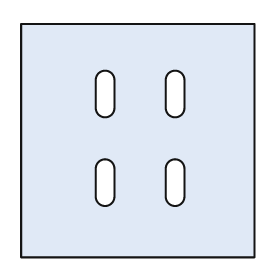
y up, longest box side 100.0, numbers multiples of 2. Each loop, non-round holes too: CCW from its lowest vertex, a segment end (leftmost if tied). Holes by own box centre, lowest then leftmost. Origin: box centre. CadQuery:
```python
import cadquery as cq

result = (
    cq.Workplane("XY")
    .moveTo(-50.0, -50.0)
    .lineTo(50.0, -50.0)
    .lineTo(50.0, 50.0)
    .lineTo(-50.0, 50.0)
    .close()
    .moveTo(-18.0, -24.0)
    .threePointArc((-14.0, -28.0), (-10.0, -24.0))
    .lineTo(-10.0, -12.0)
    .threePointArc((-14.0, -8.0), (-18.0, -12.0))
    .close()
    .moveTo(12.0, -24.0)
    .threePointArc((16.0, -28.0), (20.0, -24.0))
    .lineTo(20.0, -12.0)
    .threePointArc((16.0, -8.0), (12.0, -12.0))
    .close()
    .moveTo(-18.0, 14.0)
    .threePointArc((-14.0, 10.0), (-10.0, 14.0))
    .lineTo(-10.0, 26.0)
    .threePointArc((-14.0, 30.0), (-18.0, 26.0))
    .close()
    .moveTo(12.0, 14.0)
    .threePointArc((16.0, 10.0), (20.0, 14.0))
    .lineTo(20.0, 26.0)
    .threePointArc((16.0, 30.0), (12.0, 26.0))
    .close()
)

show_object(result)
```